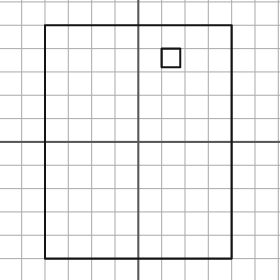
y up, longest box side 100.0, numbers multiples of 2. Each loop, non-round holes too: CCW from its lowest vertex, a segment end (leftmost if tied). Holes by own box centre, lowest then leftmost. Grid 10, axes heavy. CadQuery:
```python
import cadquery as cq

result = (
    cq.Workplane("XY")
    .moveTo(-40.0, -50.0)
    .lineTo(40.0, -50.0)
    .lineTo(40.0, 50.0)
    .lineTo(-40.0, 50.0)
    .close()
    .moveTo(10.0, 32.0)
    .lineTo(18.0, 32.0)
    .lineTo(18.0, 40.0)
    .lineTo(10.0, 40.0)
    .close()
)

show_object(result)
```